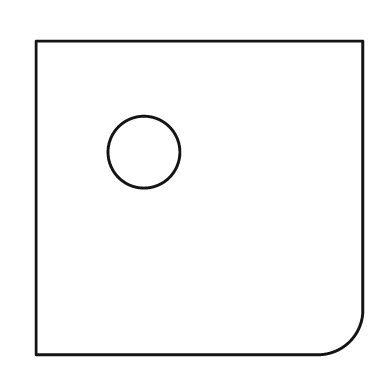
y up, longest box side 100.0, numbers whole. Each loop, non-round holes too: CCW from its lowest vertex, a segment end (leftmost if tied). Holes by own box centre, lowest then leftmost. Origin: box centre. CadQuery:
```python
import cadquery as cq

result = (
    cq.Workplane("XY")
    .moveTo(-50.0, -48.0)
    .lineTo(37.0, -48.0)
    .threePointArc((46.0, -44.0), (50.0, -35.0))
    .lineTo(50.0, 48.0)
    .lineTo(-50.0, 48.0)
    .close()
    .moveTo(-17.0, 14.0)
    .circle(11.0)
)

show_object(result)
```